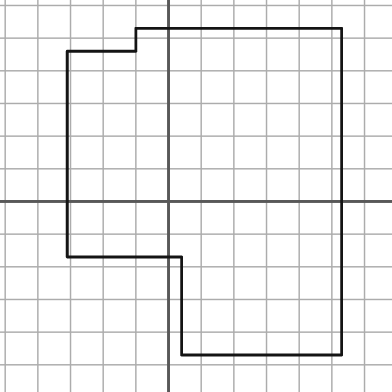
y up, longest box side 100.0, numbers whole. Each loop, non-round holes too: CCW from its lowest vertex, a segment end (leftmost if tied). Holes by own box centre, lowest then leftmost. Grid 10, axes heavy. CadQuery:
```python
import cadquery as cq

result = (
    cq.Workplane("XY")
    .moveTo(4.0, -47.0)
    .lineTo(53.0, -47.0)
    .lineTo(53.0, 53.0)
    .lineTo(-10.0, 53.0)
    .lineTo(-10.0, 46.0)
    .lineTo(-31.0, 46.0)
    .lineTo(-31.0, -17.0)
    .lineTo(4.0, -17.0)
    .close()
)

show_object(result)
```